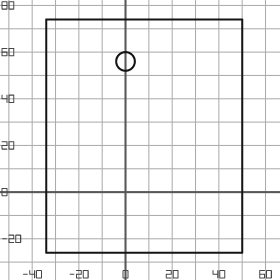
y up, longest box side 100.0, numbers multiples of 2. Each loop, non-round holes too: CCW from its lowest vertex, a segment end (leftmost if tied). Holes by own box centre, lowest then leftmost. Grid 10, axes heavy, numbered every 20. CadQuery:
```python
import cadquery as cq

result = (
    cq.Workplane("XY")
    .moveTo(-34.0, -26.0)
    .lineTo(50.0, -26.0)
    .lineTo(50.0, 74.0)
    .lineTo(-34.0, 74.0)
    .close()
    .moveTo(0.0, 56.0)
    .circle(4.0)
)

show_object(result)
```